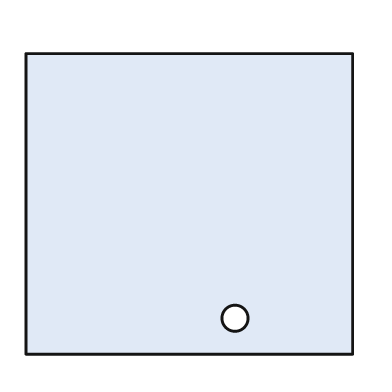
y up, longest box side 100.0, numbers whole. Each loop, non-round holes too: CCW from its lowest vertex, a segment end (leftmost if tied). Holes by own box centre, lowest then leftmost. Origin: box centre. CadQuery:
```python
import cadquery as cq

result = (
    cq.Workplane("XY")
    .moveTo(-50.0, -46.0)
    .lineTo(50.0, -46.0)
    .lineTo(50.0, 46.0)
    .lineTo(-50.0, 46.0)
    .close()
    .moveTo(14.0, -35.0)
    .circle(4.0)
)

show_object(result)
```